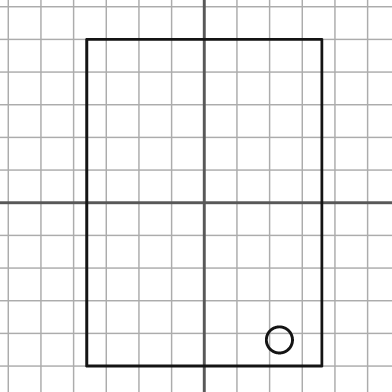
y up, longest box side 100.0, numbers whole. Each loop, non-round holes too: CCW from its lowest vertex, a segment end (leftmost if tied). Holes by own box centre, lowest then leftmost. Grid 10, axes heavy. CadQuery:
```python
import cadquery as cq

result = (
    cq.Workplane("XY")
    .moveTo(-36.0, -50.0)
    .lineTo(36.0, -50.0)
    .lineTo(36.0, 50.0)
    .lineTo(-36.0, 50.0)
    .close()
    .moveTo(23.0, -42.0)
    .circle(4.0)
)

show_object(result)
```